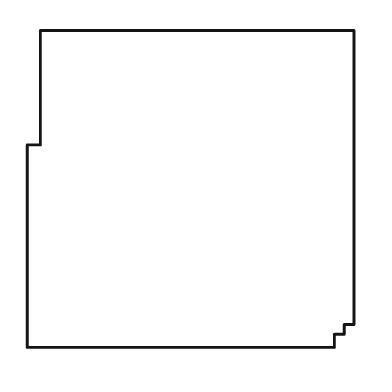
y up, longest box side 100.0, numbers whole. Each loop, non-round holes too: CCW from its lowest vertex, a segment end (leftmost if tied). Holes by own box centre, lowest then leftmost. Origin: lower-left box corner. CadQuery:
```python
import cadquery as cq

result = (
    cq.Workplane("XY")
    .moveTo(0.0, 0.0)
    .lineTo(94.0, 0.0)
    .lineTo(94.0, 4.0)
    .lineTo(97.0, 4.0)
    .lineTo(97.0, 7.0)
    .lineTo(100.0, 7.0)
    .lineTo(100.0, 97.0)
    .lineTo(4.0, 97.0)
    .lineTo(4.0, 62.0)
    .lineTo(0.0, 62.0)
    .close()
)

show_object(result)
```